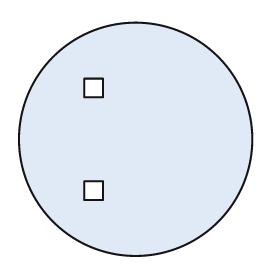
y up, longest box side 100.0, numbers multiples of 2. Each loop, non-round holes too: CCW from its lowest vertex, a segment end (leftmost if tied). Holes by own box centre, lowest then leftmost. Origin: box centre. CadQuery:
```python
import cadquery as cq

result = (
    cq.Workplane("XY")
    .moveTo(0.0, 0.0)
    .circle(50.0)
    .moveTo(-22.0, -26.0)
    .lineTo(-14.0, -26.0)
    .lineTo(-14.0, -18.0)
    .lineTo(-22.0, -18.0)
    .close()
    .moveTo(-22.0, 18.0)
    .lineTo(-14.0, 18.0)
    .lineTo(-14.0, 26.0)
    .lineTo(-22.0, 26.0)
    .close()
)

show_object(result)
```